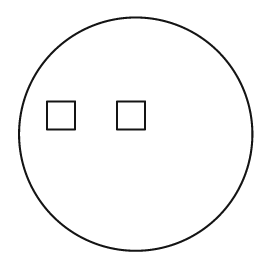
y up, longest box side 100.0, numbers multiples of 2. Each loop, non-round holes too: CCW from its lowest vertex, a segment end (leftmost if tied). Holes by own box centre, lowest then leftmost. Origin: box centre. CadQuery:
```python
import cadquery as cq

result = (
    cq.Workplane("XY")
    .moveTo(0.0, 0.0)
    .circle(50.0)
    .moveTo(-38.0, 2.0)
    .lineTo(-26.0, 2.0)
    .lineTo(-26.0, 14.0)
    .lineTo(-38.0, 14.0)
    .close()
    .moveTo(-8.0, 2.0)
    .lineTo(4.0, 2.0)
    .lineTo(4.0, 14.0)
    .lineTo(-8.0, 14.0)
    .close()
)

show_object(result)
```